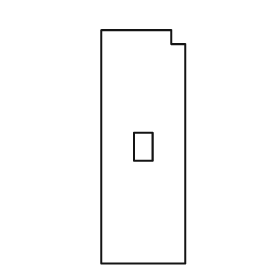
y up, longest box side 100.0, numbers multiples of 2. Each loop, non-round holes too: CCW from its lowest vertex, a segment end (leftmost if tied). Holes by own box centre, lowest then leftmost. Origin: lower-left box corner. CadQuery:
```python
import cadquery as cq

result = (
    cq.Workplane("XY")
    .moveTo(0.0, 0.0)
    .lineTo(36.0, 0.0)
    .lineTo(36.0, 94.0)
    .lineTo(30.0, 94.0)
    .lineTo(30.0, 100.0)
    .lineTo(0.0, 100.0)
    .close()
    .moveTo(14.0, 44.0)
    .lineTo(22.0, 44.0)
    .lineTo(22.0, 56.0)
    .lineTo(14.0, 56.0)
    .close()
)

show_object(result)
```